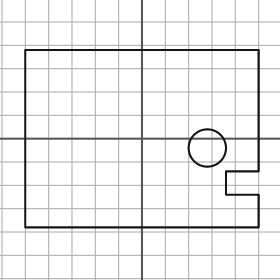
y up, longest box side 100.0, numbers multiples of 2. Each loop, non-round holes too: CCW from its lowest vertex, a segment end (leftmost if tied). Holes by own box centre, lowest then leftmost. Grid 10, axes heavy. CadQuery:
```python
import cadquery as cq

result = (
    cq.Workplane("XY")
    .moveTo(-50.0, -38.0)
    .lineTo(50.0, -38.0)
    .lineTo(50.0, -24.0)
    .lineTo(36.0, -24.0)
    .lineTo(36.0, -14.0)
    .lineTo(50.0, -14.0)
    .lineTo(50.0, 38.0)
    .lineTo(-50.0, 38.0)
    .close()
    .moveTo(28.0, -4.0)
    .circle(8.0)
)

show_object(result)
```